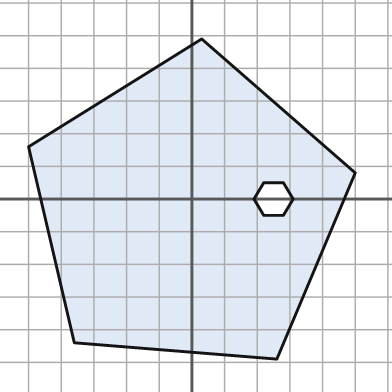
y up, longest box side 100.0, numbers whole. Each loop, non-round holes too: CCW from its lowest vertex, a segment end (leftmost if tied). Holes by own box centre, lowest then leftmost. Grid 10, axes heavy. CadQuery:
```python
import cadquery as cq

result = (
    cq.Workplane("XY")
    .moveTo(26.0, -49.0)
    .lineTo(50.0, 8.0)
    .lineTo(3.0, 49.0)
    .lineTo(-50.0, 16.0)
    .lineTo(-36.0, -44.0)
    .close()
    .moveTo(22.0, -5.0)
    .lineTo(28.0, -5.0)
    .lineTo(31.0, 0.0)
    .lineTo(28.0, 5.0)
    .lineTo(22.0, 5.0)
    .lineTo(19.0, 0.0)
    .close()
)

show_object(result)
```